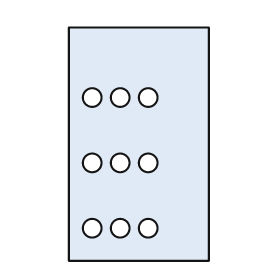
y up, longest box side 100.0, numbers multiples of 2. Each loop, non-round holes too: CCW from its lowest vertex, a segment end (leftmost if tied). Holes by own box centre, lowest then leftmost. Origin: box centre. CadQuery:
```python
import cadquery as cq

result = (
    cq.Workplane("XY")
    .moveTo(-30.0, -50.0)
    .lineTo(30.0, -50.0)
    .lineTo(30.0, 50.0)
    .lineTo(-30.0, 50.0)
    .close()
    .moveTo(-20.0, -36.0)
    .circle(4.0)
    .moveTo(-8.0, -36.0)
    .circle(4.0)
    .moveTo(4.0, -36.0)
    .circle(4.0)
    .moveTo(-20.0, -8.0)
    .circle(4.0)
    .moveTo(-8.0, -8.0)
    .circle(4.0)
    .moveTo(4.0, -8.0)
    .circle(4.0)
    .moveTo(-20.0, 20.0)
    .circle(4.0)
    .moveTo(-8.0, 20.0)
    .circle(4.0)
    .moveTo(4.0, 20.0)
    .circle(4.0)
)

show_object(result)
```